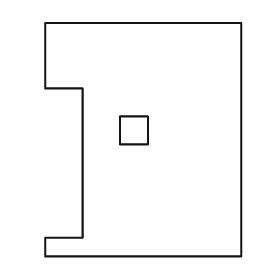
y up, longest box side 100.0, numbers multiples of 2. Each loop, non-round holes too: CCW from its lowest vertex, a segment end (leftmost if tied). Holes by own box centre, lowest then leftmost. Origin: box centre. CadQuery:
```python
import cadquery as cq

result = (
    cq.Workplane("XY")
    .moveTo(-42.0, -50.0)
    .lineTo(42.0, -50.0)
    .lineTo(42.0, 50.0)
    .lineTo(-42.0, 50.0)
    .lineTo(-42.0, 22.0)
    .lineTo(-26.0, 22.0)
    .lineTo(-26.0, -42.0)
    .lineTo(-42.0, -42.0)
    .close()
    .moveTo(-10.0, -2.0)
    .lineTo(2.0, -2.0)
    .lineTo(2.0, 10.0)
    .lineTo(-10.0, 10.0)
    .close()
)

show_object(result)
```